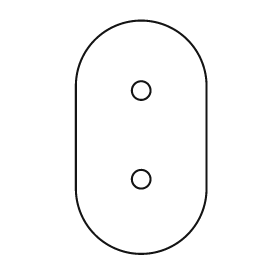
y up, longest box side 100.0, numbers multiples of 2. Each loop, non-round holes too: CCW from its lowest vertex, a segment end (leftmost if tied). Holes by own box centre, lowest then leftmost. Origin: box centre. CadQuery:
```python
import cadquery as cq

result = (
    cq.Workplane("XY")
    .moveTo(-28.0, -22.0)
    .threePointArc((0.0, -50.0), (28.0, -22.0))
    .lineTo(28.0, 22.0)
    .threePointArc((0.0, 50.0), (-28.0, 22.0))
    .close()
    .moveTo(0.0, -18.0)
    .circle(4.0)
    .moveTo(0.0, 20.0)
    .circle(4.0)
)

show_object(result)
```